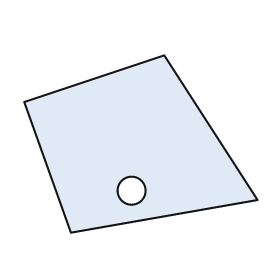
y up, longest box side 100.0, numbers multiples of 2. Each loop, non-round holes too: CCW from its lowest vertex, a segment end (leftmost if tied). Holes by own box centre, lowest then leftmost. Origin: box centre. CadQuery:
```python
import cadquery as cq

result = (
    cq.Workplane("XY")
    .moveTo(-30.0, -38.0)
    .lineTo(50.0, -24.0)
    .lineTo(10.0, 38.0)
    .lineTo(-50.0, 18.0)
    .close()
    .moveTo(-4.0, -20.0)
    .circle(6.0)
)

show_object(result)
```